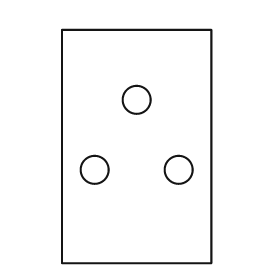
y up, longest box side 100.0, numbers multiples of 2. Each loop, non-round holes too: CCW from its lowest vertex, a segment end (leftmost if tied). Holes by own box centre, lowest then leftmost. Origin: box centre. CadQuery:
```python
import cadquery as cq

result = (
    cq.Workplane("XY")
    .moveTo(-32.0, -50.0)
    .lineTo(32.0, -50.0)
    .lineTo(32.0, 50.0)
    .lineTo(-32.0, 50.0)
    .close()
    .moveTo(-18.0, -10.0)
    .circle(6.0)
    .moveTo(18.0, -10.0)
    .circle(6.0)
    .moveTo(0.0, 20.0)
    .circle(6.0)
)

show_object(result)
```